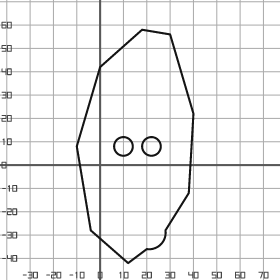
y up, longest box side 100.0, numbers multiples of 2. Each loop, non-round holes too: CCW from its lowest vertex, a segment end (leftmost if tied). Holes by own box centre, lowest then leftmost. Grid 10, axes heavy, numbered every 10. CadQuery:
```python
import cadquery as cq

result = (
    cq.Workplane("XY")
    .moveTo(12.0, -42.0)
    .lineTo(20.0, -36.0)
    .threePointArc((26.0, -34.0), (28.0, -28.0))
    .lineTo(38.0, -12.0)
    .lineTo(40.0, 22.0)
    .lineTo(30.0, 56.0)
    .lineTo(18.0, 58.0)
    .lineTo(0.0, 42.0)
    .lineTo(-10.0, 8.0)
    .lineTo(-4.0, -28.0)
    .close()
    .moveTo(10.0, 8.0)
    .circle(4.0)
    .moveTo(22.0, 8.0)
    .circle(4.0)
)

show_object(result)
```